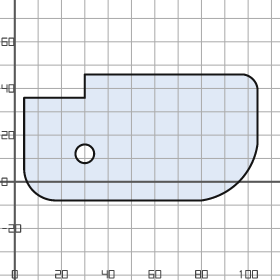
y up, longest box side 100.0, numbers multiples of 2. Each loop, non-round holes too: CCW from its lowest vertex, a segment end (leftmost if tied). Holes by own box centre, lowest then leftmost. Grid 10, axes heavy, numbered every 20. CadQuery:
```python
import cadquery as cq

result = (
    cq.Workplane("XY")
    .moveTo(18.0, -8.0)
    .lineTo(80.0, -8.0)
    .threePointArc((96.0, 0.0), (104.0, 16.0))
    .lineTo(104.0, 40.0)
    .threePointArc((102.0, 44.0), (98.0, 46.0))
    .lineTo(30.0, 46.0)
    .lineTo(30.0, 36.0)
    .lineTo(4.0, 36.0)
    .lineTo(4.0, 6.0)
    .threePointArc((8.0, -4.0), (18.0, -8.0))
    .close()
    .moveTo(30.0, 12.0)
    .circle(4.0)
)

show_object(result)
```